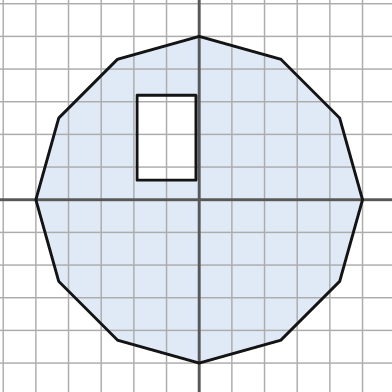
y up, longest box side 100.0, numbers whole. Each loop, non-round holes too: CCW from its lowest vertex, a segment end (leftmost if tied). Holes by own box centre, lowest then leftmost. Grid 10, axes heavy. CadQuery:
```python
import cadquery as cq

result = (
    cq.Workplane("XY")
    .moveTo(0.0, -50.0)
    .lineTo(25.0, -43.0)
    .lineTo(43.0, -25.0)
    .lineTo(50.0, 0.0)
    .lineTo(43.0, 25.0)
    .lineTo(25.0, 43.0)
    .lineTo(0.0, 50.0)
    .lineTo(-25.0, 43.0)
    .lineTo(-43.0, 25.0)
    .lineTo(-50.0, 0.0)
    .lineTo(-43.0, -25.0)
    .lineTo(-25.0, -43.0)
    .close()
    .moveTo(-19.0, 6.0)
    .lineTo(-1.0, 6.0)
    .lineTo(-1.0, 32.0)
    .lineTo(-19.0, 32.0)
    .close()
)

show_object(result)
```